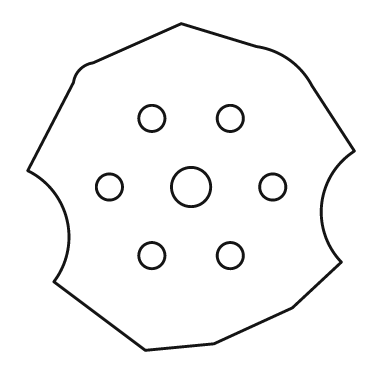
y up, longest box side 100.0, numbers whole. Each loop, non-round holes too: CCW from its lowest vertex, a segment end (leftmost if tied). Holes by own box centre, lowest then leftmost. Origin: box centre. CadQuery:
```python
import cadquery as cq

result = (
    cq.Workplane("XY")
    .moveTo(-14.0, -50.0)
    .lineTo(7.0, -48.0)
    .lineTo(31.0, -37.0)
    .lineTo(46.0, -23.0)
    .threePointArc((40.0, -5.0), (50.0, 11.0))
    .lineTo(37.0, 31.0)
    .threePointArc((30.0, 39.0), (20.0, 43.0))
    .lineTo(-3.0, 50.0)
    .lineTo(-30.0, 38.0)
    .threePointArc((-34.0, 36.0), (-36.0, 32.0))
    .lineTo(-50.0, 5.0)
    .threePointArc((-38.0, -10.0), (-42.0, -29.0))
    .close()
    .moveTo(-12.0, -21.0)
    .circle(4.0)
    .moveTo(12.0, -21.0)
    .circle(4.0)
    .moveTo(-25.0, 0.0)
    .circle(4.0)
    .moveTo(0.0, 0.0)
    .circle(6.0)
    .moveTo(25.0, 0.0)
    .circle(4.0)
    .moveTo(-12.0, 21.0)
    .circle(4.0)
    .moveTo(12.0, 21.0)
    .circle(4.0)
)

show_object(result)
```